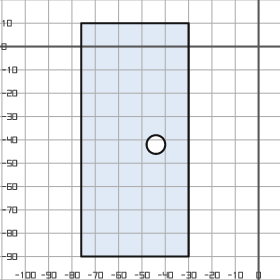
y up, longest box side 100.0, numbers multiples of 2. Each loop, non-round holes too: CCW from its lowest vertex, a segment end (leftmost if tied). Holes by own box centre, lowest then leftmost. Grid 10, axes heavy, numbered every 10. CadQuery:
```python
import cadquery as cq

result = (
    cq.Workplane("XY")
    .moveTo(-76.0, -90.0)
    .lineTo(-30.0, -90.0)
    .lineTo(-30.0, 10.0)
    .lineTo(-76.0, 10.0)
    .close()
    .moveTo(-44.0, -42.0)
    .circle(4.0)
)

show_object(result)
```